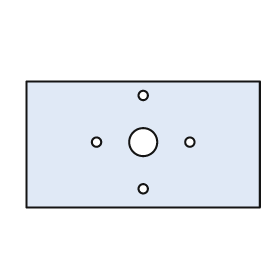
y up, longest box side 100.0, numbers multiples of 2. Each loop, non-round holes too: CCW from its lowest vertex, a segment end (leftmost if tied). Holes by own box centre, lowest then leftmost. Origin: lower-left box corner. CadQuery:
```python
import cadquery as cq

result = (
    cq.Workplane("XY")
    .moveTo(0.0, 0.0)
    .lineTo(100.0, 0.0)
    .lineTo(100.0, 54.0)
    .lineTo(0.0, 54.0)
    .close()
    .moveTo(50.0, 8.0)
    .circle(2.0)
    .moveTo(30.0, 28.0)
    .circle(2.0)
    .moveTo(50.0, 28.0)
    .circle(6.0)
    .moveTo(70.0, 28.0)
    .circle(2.0)
    .moveTo(50.0, 48.0)
    .circle(2.0)
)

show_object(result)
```